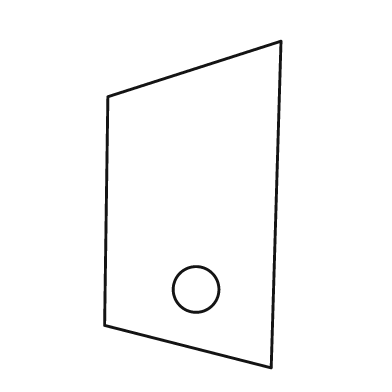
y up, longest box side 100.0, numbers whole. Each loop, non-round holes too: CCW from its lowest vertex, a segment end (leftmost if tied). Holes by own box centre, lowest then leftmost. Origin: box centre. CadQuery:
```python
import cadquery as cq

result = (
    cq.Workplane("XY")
    .moveTo(24.0, -50.0)
    .lineTo(27.0, 50.0)
    .lineTo(-26.0, 33.0)
    .lineTo(-27.0, -37.0)
    .close()
    .moveTo(1.0, -26.0)
    .circle(7.0)
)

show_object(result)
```